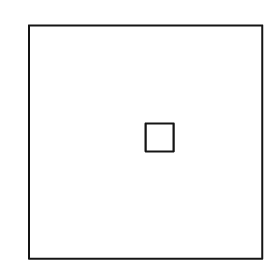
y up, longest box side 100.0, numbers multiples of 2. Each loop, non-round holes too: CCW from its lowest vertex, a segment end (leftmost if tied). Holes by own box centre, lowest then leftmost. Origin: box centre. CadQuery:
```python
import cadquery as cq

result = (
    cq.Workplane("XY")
    .moveTo(-50.0, -50.0)
    .lineTo(50.0, -50.0)
    .lineTo(50.0, 50.0)
    .lineTo(-50.0, 50.0)
    .close()
    .moveTo(0.0, -4.0)
    .lineTo(12.0, -4.0)
    .lineTo(12.0, 8.0)
    .lineTo(0.0, 8.0)
    .close()
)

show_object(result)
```